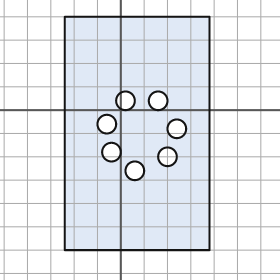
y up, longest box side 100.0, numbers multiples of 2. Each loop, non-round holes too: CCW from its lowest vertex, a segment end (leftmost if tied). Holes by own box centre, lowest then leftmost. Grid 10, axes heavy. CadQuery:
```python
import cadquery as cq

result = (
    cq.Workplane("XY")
    .moveTo(-24.0, -60.0)
    .lineTo(38.0, -60.0)
    .lineTo(38.0, 40.0)
    .lineTo(-24.0, 40.0)
    .close()
    .moveTo(6.0, -26.0)
    .circle(4.0)
    .moveTo(20.0, -20.0)
    .circle(4.0)
    .moveTo(-4.0, -18.0)
    .circle(4.0)
    .moveTo(24.0, -8.0)
    .circle(4.0)
    .moveTo(-6.0, -6.0)
    .circle(4.0)
    .moveTo(2.0, 4.0)
    .circle(4.0)
    .moveTo(16.0, 4.0)
    .circle(4.0)
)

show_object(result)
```